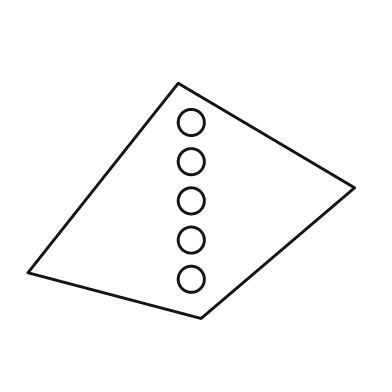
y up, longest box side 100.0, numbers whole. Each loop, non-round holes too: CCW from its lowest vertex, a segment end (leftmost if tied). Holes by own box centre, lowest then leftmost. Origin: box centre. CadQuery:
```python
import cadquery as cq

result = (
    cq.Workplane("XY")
    .moveTo(3.0, -36.0)
    .lineTo(50.0, 4.0)
    .lineTo(-4.0, 36.0)
    .lineTo(-50.0, -22.0)
    .close()
    .moveTo(0.0, -24.0)
    .circle(4.0)
    .moveTo(0.0, -12.0)
    .circle(4.0)
    .moveTo(0.0, 0.0)
    .circle(4.0)
    .moveTo(0.0, 12.0)
    .circle(4.0)
    .moveTo(0.0, 24.0)
    .circle(4.0)
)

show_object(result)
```